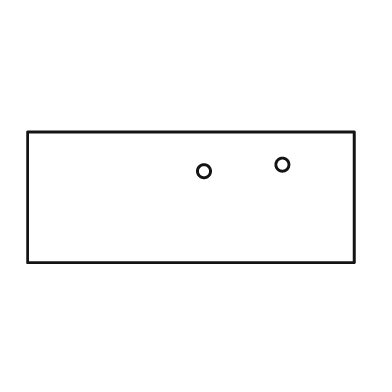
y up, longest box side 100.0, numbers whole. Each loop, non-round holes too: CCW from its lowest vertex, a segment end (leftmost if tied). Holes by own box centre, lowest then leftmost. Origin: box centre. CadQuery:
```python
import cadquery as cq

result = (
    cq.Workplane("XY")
    .moveTo(-50.0, -20.0)
    .lineTo(50.0, -20.0)
    .lineTo(50.0, 20.0)
    .lineTo(-50.0, 20.0)
    .close()
    .moveTo(4.0, 8.0)
    .circle(2.0)
    .moveTo(28.0, 10.0)
    .circle(2.0)
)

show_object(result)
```